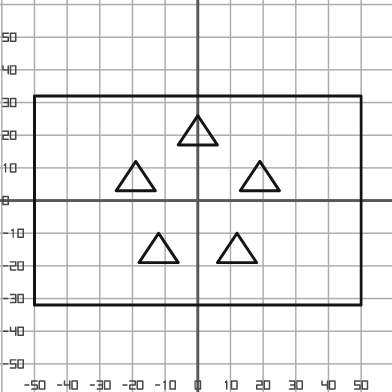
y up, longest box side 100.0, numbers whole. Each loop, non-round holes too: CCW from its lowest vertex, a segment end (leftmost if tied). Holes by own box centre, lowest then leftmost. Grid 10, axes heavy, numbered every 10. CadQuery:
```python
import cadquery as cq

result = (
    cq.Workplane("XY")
    .moveTo(-50.0, -32.0)
    .lineTo(50.0, -32.0)
    .lineTo(50.0, 32.0)
    .lineTo(-50.0, 32.0)
    .close()
    .moveTo(-18.0, -19.0)
    .lineTo(-6.0, -19.0)
    .lineTo(-12.0, -10.0)
    .close()
    .moveTo(6.0, -19.0)
    .lineTo(18.0, -19.0)
    .lineTo(12.0, -10.0)
    .close()
    .moveTo(-25.0, 3.0)
    .lineTo(-13.0, 3.0)
    .lineTo(-19.0, 12.0)
    .close()
    .moveTo(13.0, 3.0)
    .lineTo(25.0, 3.0)
    .lineTo(19.0, 12.0)
    .close()
    .moveTo(-6.0, 17.0)
    .lineTo(6.0, 17.0)
    .lineTo(0.0, 26.0)
    .close()
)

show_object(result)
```